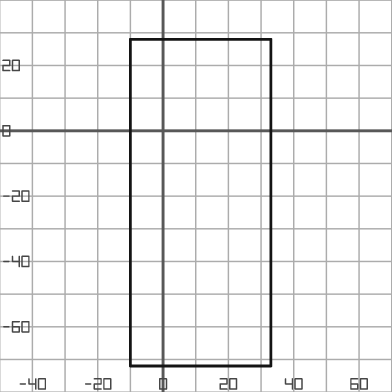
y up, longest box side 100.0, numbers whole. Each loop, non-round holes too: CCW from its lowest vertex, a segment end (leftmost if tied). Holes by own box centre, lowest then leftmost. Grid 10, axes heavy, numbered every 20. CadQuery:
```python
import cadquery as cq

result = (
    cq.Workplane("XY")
    .moveTo(-10.0, -72.0)
    .lineTo(33.0, -72.0)
    .lineTo(33.0, 28.0)
    .lineTo(-10.0, 28.0)
    .close()
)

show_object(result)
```